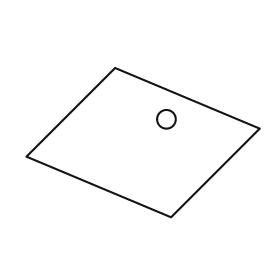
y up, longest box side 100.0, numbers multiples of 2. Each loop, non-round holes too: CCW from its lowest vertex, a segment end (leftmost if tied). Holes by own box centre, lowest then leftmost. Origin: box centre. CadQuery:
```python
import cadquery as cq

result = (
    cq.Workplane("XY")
    .moveTo(12.0, -32.0)
    .lineTo(50.0, 6.0)
    .lineTo(-12.0, 32.0)
    .lineTo(-50.0, -6.0)
    .close()
    .moveTo(10.0, 10.0)
    .circle(4.0)
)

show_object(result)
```